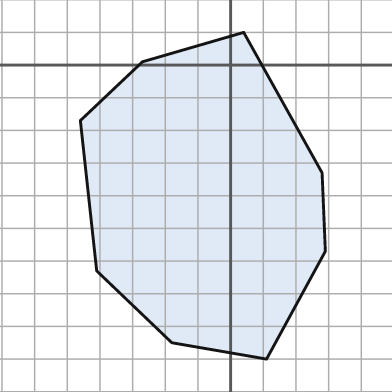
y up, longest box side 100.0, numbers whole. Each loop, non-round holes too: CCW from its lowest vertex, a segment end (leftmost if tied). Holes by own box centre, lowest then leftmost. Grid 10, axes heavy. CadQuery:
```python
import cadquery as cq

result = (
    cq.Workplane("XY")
    .moveTo(11.0, -90.0)
    .lineTo(29.0, -57.0)
    .lineTo(28.0, -33.0)
    .lineTo(4.0, 10.0)
    .lineTo(-27.0, 1.0)
    .lineTo(-46.0, -17.0)
    .lineTo(-41.0, -63.0)
    .lineTo(-18.0, -85.0)
    .close()
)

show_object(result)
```